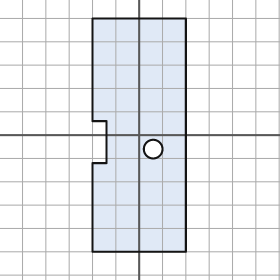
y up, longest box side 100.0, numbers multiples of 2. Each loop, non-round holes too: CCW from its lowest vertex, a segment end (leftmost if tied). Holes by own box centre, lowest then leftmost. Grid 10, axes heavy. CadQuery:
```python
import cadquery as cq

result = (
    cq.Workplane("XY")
    .moveTo(-20.0, -50.0)
    .lineTo(20.0, -50.0)
    .lineTo(20.0, 50.0)
    .lineTo(-20.0, 50.0)
    .lineTo(-20.0, 6.0)
    .lineTo(-14.0, 6.0)
    .lineTo(-14.0, -12.0)
    .lineTo(-20.0, -12.0)
    .close()
    .moveTo(6.0, -6.0)
    .circle(4.0)
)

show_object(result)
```